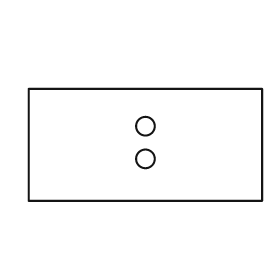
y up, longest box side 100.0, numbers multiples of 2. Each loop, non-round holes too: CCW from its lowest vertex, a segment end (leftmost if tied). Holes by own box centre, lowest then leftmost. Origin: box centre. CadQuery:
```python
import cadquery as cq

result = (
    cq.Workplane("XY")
    .moveTo(-50.0, -24.0)
    .lineTo(50.0, -24.0)
    .lineTo(50.0, 24.0)
    .lineTo(-50.0, 24.0)
    .close()
    .moveTo(0.0, -6.0)
    .circle(4.0)
    .moveTo(0.0, 8.0)
    .circle(4.0)
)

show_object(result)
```